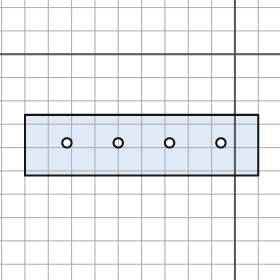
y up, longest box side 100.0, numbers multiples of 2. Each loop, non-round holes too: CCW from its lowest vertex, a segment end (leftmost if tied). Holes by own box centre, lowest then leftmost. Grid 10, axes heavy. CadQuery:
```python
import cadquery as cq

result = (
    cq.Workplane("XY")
    .moveTo(-90.0, -52.0)
    .lineTo(10.0, -52.0)
    .lineTo(10.0, -26.0)
    .lineTo(-90.0, -26.0)
    .close()
    .moveTo(-72.0, -38.0)
    .circle(2.0)
    .moveTo(-50.0, -38.0)
    .circle(2.0)
    .moveTo(-28.0, -38.0)
    .circle(2.0)
    .moveTo(-6.0, -38.0)
    .circle(2.0)
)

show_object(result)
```